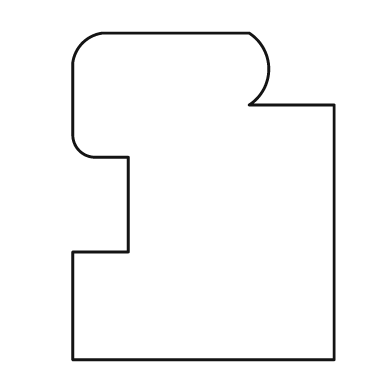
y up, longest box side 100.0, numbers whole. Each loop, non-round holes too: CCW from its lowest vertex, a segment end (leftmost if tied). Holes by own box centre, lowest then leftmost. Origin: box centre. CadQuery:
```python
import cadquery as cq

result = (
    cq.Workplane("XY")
    .moveTo(-40.0, -50.0)
    .lineTo(40.0, -50.0)
    .lineTo(40.0, 28.0)
    .lineTo(14.0, 28.0)
    .threePointArc((20.0, 39.0), (14.0, 50.0))
    .lineTo(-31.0, 50.0)
    .threePointArc((-37.0, 47.0), (-40.0, 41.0))
    .lineTo(-40.0, 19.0)
    .threePointArc((-38.0, 14.0), (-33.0, 12.0))
    .lineTo(-23.0, 12.0)
    .lineTo(-23.0, -17.0)
    .lineTo(-40.0, -17.0)
    .close()
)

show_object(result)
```